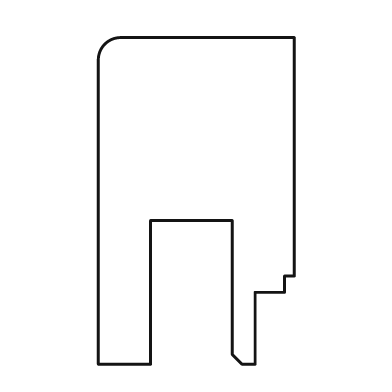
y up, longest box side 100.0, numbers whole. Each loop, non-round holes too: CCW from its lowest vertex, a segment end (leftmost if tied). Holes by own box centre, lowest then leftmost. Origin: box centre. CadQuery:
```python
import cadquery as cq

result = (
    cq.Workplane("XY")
    .moveTo(-30.0, -50.0)
    .lineTo(-14.0, -50.0)
    .lineTo(-14.0, -6.0)
    .lineTo(11.0, -6.0)
    .lineTo(11.0, -47.0)
    .lineTo(14.0, -50.0)
    .lineTo(18.0, -50.0)
    .lineTo(18.0, -28.0)
    .lineTo(27.0, -28.0)
    .lineTo(27.0, -23.0)
    .lineTo(30.0, -23.0)
    .lineTo(30.0, 50.0)
    .lineTo(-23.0, 50.0)
    .threePointArc((-28.0, 48.0), (-30.0, 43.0))
    .close()
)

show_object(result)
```